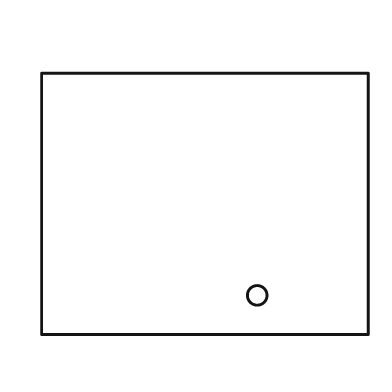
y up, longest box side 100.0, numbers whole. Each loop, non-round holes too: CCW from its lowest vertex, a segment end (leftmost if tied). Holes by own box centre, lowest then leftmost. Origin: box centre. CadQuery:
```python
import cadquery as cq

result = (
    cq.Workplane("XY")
    .moveTo(-50.0, -40.0)
    .lineTo(50.0, -40.0)
    .lineTo(50.0, 40.0)
    .lineTo(-50.0, 40.0)
    .close()
    .moveTo(16.0, -28.0)
    .circle(3.0)
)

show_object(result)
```